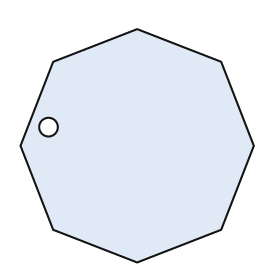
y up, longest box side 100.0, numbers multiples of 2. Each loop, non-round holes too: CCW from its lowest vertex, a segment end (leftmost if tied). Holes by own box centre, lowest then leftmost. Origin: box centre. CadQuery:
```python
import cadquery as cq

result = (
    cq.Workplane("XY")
    .moveTo(0.0, -50.0)
    .lineTo(36.0, -36.0)
    .lineTo(50.0, 0.0)
    .lineTo(36.0, 36.0)
    .lineTo(0.0, 50.0)
    .lineTo(-36.0, 36.0)
    .lineTo(-50.0, 0.0)
    .lineTo(-36.0, -36.0)
    .close()
    .moveTo(-38.0, 8.0)
    .circle(4.0)
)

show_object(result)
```